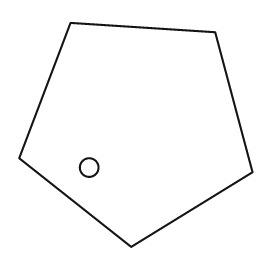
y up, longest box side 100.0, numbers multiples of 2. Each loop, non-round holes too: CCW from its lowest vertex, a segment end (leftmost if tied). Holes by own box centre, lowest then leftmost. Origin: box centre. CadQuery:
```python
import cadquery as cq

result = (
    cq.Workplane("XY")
    .moveTo(-2.0, -48.0)
    .lineTo(50.0, -16.0)
    .lineTo(34.0, 44.0)
    .lineTo(-28.0, 48.0)
    .lineTo(-50.0, -10.0)
    .close()
    .moveTo(-20.0, -14.0)
    .circle(4.0)
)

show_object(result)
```